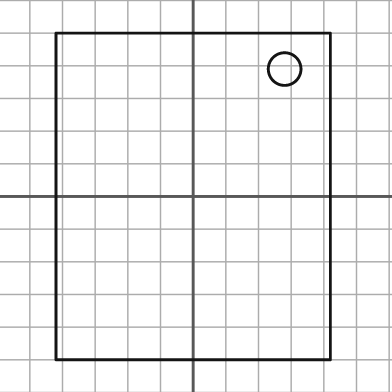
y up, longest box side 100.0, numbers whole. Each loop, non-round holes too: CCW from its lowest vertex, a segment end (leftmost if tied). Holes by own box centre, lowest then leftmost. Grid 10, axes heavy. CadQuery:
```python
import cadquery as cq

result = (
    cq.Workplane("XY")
    .moveTo(-42.0, -50.0)
    .lineTo(42.0, -50.0)
    .lineTo(42.0, 50.0)
    .lineTo(-42.0, 50.0)
    .close()
    .moveTo(28.0, 39.0)
    .circle(5.0)
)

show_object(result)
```